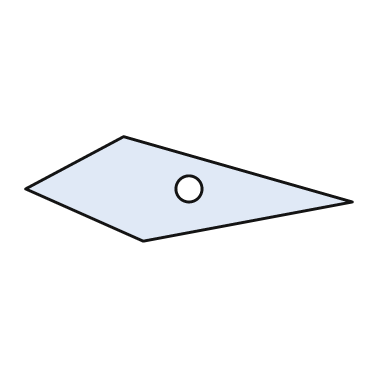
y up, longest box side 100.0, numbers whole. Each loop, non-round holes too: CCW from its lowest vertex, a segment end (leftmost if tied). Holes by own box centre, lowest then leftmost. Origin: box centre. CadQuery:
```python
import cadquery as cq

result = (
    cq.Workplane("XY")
    .moveTo(-14.0, -16.0)
    .lineTo(50.0, -4.0)
    .lineTo(-20.0, 16.0)
    .lineTo(-50.0, 0.0)
    .close()
    .moveTo(0.0, 0.0)
    .circle(4.0)
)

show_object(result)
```